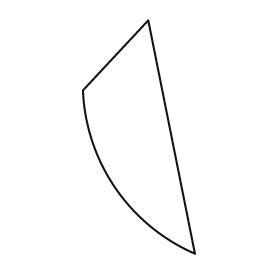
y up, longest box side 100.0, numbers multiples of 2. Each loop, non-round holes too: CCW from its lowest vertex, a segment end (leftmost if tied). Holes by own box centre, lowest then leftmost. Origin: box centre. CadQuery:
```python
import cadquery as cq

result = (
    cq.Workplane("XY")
    .moveTo(24.0, -50.0)
    .lineTo(4.0, 50.0)
    .lineTo(-24.0, 20.0)
    .threePointArc((-10.0, -22.0), (24.0, -50.0))
    .close()
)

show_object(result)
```